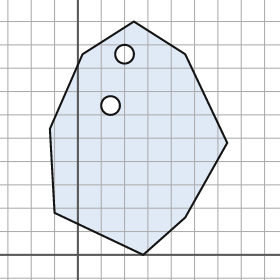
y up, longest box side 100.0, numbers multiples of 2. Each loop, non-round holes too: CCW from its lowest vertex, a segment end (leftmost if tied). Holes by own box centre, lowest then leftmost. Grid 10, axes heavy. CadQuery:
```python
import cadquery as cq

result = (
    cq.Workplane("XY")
    .moveTo(28.0, 0.0)
    .lineTo(46.0, 16.0)
    .lineTo(64.0, 48.0)
    .lineTo(46.0, 86.0)
    .lineTo(24.0, 100.0)
    .lineTo(2.0, 86.0)
    .lineTo(-12.0, 54.0)
    .lineTo(-10.0, 18.0)
    .close()
    .moveTo(14.0, 64.0)
    .circle(4.0)
    .moveTo(20.0, 86.0)
    .circle(4.0)
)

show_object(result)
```